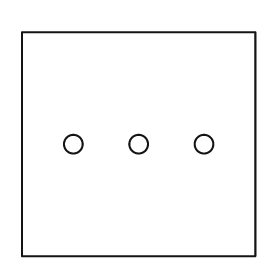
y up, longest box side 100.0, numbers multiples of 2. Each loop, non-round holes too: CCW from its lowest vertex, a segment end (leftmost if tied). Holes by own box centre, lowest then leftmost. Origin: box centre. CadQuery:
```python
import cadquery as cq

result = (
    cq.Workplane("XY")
    .moveTo(-50.0, -48.0)
    .lineTo(50.0, -48.0)
    .lineTo(50.0, 48.0)
    .lineTo(-50.0, 48.0)
    .close()
    .moveTo(-28.0, 0.0)
    .circle(4.0)
    .moveTo(0.0, 0.0)
    .circle(4.0)
    .moveTo(28.0, 0.0)
    .circle(4.0)
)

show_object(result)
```